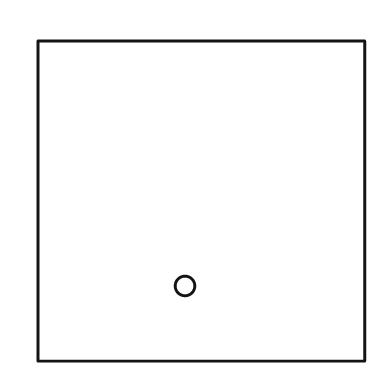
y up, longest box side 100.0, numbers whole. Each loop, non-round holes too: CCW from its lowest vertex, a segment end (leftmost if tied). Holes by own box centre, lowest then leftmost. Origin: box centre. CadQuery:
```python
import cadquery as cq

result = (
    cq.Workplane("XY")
    .moveTo(-50.0, -49.0)
    .lineTo(50.0, -49.0)
    .lineTo(50.0, 49.0)
    .lineTo(-50.0, 49.0)
    .close()
    .moveTo(-5.0, -26.0)
    .circle(3.0)
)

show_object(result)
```